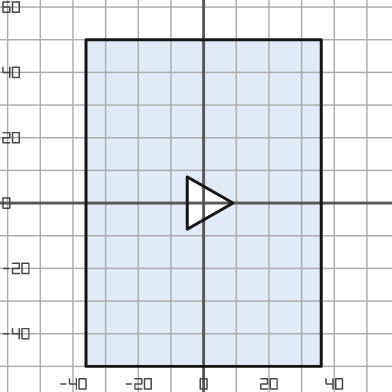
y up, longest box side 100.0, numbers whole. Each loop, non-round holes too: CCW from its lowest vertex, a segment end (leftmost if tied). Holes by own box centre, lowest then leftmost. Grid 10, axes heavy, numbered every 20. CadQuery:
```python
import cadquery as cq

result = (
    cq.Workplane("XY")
    .moveTo(-36.0, -50.0)
    .lineTo(36.0, -50.0)
    .lineTo(36.0, 50.0)
    .lineTo(-36.0, 50.0)
    .close()
    .moveTo(-5.0, -8.0)
    .lineTo(9.0, 0.0)
    .lineTo(-5.0, 8.0)
    .close()
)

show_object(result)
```